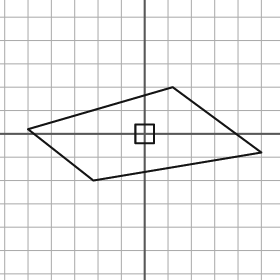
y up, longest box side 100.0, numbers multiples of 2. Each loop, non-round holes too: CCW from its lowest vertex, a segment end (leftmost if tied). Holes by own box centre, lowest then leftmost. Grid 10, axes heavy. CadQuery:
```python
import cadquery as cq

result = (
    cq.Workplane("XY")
    .moveTo(-22.0, -20.0)
    .lineTo(50.0, -8.0)
    .lineTo(12.0, 20.0)
    .lineTo(-50.0, 2.0)
    .close()
    .moveTo(-4.0, -4.0)
    .lineTo(4.0, -4.0)
    .lineTo(4.0, 4.0)
    .lineTo(-4.0, 4.0)
    .close()
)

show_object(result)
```